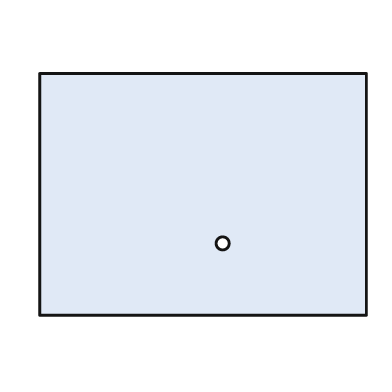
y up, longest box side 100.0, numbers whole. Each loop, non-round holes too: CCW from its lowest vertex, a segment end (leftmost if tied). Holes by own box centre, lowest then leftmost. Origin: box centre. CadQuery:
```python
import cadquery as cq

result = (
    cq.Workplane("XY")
    .moveTo(-50.0, -37.0)
    .lineTo(50.0, -37.0)
    .lineTo(50.0, 37.0)
    .lineTo(-50.0, 37.0)
    .close()
    .moveTo(6.0, -15.0)
    .circle(2.0)
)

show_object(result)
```